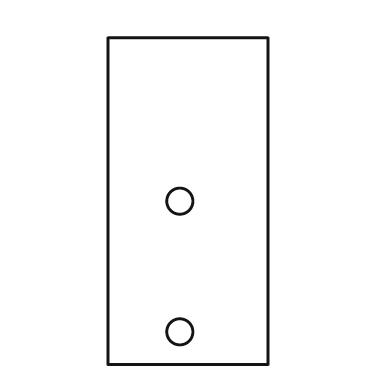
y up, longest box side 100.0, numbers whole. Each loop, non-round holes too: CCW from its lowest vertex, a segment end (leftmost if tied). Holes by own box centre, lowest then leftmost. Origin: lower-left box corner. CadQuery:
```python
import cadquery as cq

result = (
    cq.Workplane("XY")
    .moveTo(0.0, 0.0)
    .lineTo(49.0, 0.0)
    .lineTo(49.0, 100.0)
    .lineTo(0.0, 100.0)
    .close()
    .moveTo(22.0, 10.0)
    .circle(4.0)
    .moveTo(22.0, 50.0)
    .circle(4.0)
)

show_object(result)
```